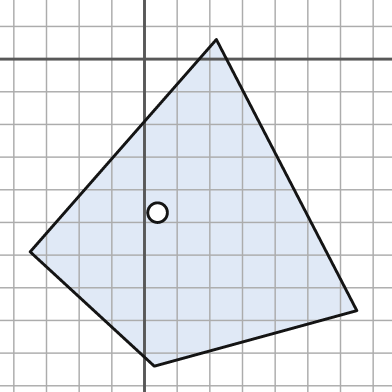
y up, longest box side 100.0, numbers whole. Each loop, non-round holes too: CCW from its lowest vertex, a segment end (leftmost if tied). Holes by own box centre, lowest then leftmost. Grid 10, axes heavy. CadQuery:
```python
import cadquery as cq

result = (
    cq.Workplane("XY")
    .moveTo(3.0, -94.0)
    .lineTo(65.0, -77.0)
    .lineTo(22.0, 6.0)
    .lineTo(-35.0, -59.0)
    .close()
    .moveTo(4.0, -47.0)
    .circle(3.0)
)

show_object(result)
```